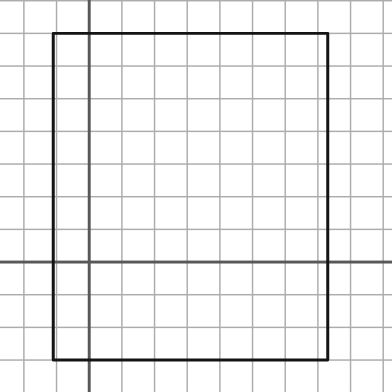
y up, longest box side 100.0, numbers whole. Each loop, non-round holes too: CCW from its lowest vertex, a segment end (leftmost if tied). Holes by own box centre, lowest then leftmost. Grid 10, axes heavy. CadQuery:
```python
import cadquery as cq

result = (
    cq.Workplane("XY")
    .moveTo(-11.0, -30.0)
    .lineTo(73.0, -30.0)
    .lineTo(73.0, 70.0)
    .lineTo(-11.0, 70.0)
    .close()
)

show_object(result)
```